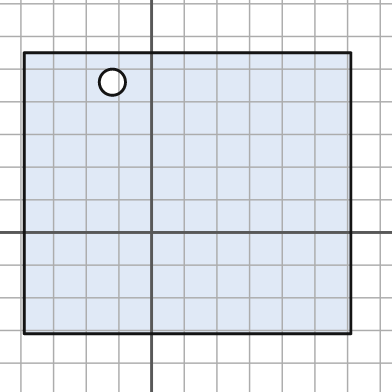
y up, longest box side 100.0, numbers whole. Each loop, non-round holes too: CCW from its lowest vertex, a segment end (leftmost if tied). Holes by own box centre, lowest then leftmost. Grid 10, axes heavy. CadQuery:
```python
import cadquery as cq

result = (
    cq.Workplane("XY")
    .moveTo(-39.0, -31.0)
    .lineTo(61.0, -31.0)
    .lineTo(61.0, 55.0)
    .lineTo(-39.0, 55.0)
    .close()
    .moveTo(-12.0, 46.0)
    .circle(4.0)
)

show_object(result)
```